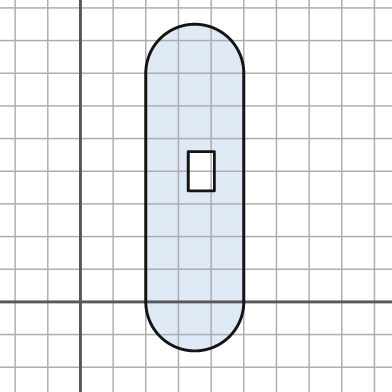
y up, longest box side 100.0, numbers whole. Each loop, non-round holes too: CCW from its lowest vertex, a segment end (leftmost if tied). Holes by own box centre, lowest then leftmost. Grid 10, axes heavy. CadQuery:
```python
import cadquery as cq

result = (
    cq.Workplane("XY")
    .moveTo(20.0, 0.0)
    .threePointArc((35.0, -15.0), (50.0, 0.0))
    .lineTo(50.0, 70.0)
    .threePointArc((35.0, 85.0), (20.0, 70.0))
    .close()
    .moveTo(33.0, 34.0)
    .lineTo(41.0, 34.0)
    .lineTo(41.0, 46.0)
    .lineTo(33.0, 46.0)
    .close()
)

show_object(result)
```